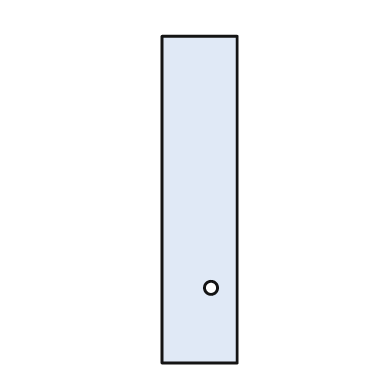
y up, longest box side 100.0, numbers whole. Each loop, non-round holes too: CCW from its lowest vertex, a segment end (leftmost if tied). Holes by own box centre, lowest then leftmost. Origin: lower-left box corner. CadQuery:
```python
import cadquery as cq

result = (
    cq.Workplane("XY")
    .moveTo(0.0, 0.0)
    .lineTo(23.0, 0.0)
    .lineTo(23.0, 100.0)
    .lineTo(0.0, 100.0)
    .close()
    .moveTo(15.0, 23.0)
    .circle(2.0)
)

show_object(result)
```